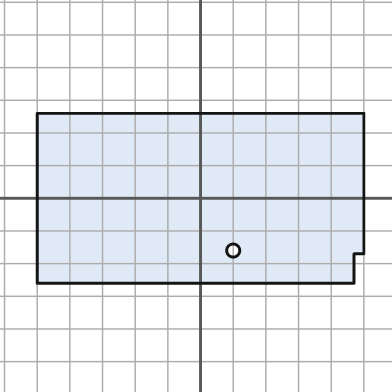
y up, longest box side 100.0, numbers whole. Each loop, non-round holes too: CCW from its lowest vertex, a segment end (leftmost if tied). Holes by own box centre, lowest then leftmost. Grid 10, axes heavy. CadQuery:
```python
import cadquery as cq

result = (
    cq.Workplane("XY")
    .moveTo(-50.0, -26.0)
    .lineTo(47.0, -26.0)
    .lineTo(47.0, -17.0)
    .lineTo(50.0, -17.0)
    .lineTo(50.0, 26.0)
    .lineTo(-50.0, 26.0)
    .close()
    .moveTo(10.0, -16.0)
    .circle(2.0)
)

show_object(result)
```